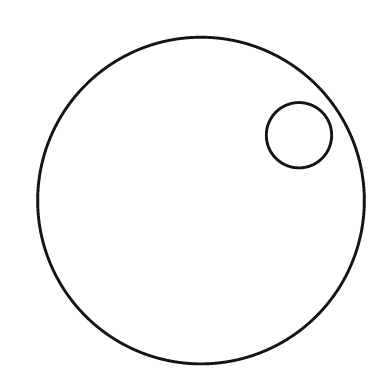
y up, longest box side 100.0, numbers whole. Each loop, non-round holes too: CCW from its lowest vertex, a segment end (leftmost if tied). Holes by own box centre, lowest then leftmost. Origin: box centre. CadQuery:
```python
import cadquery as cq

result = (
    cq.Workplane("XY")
    .moveTo(0.0, 0.0)
    .circle(50.0)
    .moveTo(30.0, 20.0)
    .circle(10.0)
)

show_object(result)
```